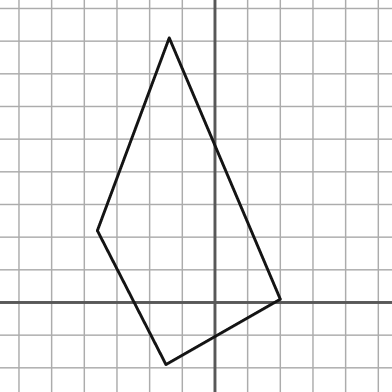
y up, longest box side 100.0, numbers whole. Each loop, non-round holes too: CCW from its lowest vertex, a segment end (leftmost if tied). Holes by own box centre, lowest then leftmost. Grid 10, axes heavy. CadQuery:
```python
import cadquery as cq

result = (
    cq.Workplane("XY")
    .moveTo(-15.0, -19.0)
    .lineTo(20.0, 1.0)
    .lineTo(-14.0, 81.0)
    .lineTo(-36.0, 22.0)
    .close()
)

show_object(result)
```